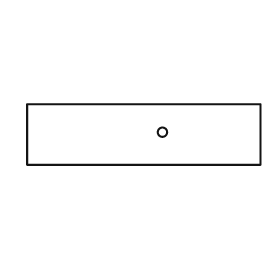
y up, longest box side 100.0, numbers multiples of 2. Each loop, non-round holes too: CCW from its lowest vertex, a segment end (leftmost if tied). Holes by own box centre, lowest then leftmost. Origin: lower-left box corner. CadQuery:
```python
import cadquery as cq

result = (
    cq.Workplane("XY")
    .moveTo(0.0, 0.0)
    .lineTo(100.0, 0.0)
    .lineTo(100.0, 26.0)
    .lineTo(0.0, 26.0)
    .close()
    .moveTo(58.0, 14.0)
    .circle(2.0)
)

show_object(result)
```